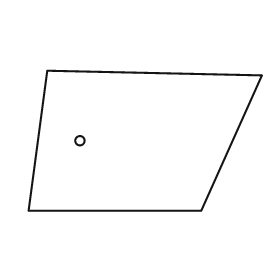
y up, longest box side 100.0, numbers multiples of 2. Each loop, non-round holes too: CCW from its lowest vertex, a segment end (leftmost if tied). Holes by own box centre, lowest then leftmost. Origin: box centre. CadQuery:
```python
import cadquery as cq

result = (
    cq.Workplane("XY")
    .moveTo(-50.0, -30.0)
    .lineTo(24.0, -30.0)
    .lineTo(50.0, 28.0)
    .lineTo(-42.0, 30.0)
    .close()
    .moveTo(-28.0, 0.0)
    .circle(2.0)
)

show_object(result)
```